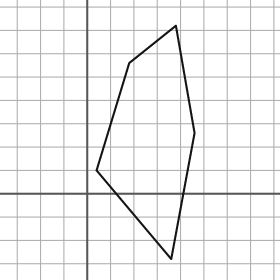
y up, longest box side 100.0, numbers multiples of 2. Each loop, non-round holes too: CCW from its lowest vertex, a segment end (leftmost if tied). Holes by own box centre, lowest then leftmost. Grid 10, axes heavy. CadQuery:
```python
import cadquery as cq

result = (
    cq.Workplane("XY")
    .moveTo(36.0, -28.0)
    .lineTo(46.0, 26.0)
    .lineTo(38.0, 72.0)
    .lineTo(18.0, 56.0)
    .lineTo(4.0, 10.0)
    .close()
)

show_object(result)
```